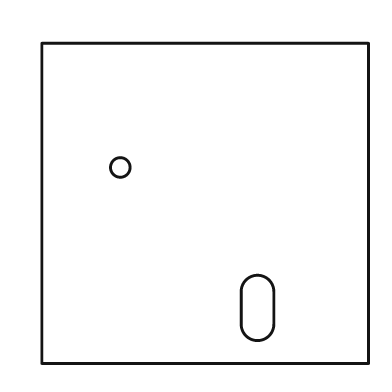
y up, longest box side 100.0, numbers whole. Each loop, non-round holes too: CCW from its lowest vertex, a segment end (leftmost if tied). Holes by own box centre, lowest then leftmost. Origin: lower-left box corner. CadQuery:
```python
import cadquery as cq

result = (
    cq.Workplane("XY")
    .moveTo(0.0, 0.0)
    .lineTo(100.0, 0.0)
    .lineTo(100.0, 98.0)
    .lineTo(0.0, 98.0)
    .close()
    .moveTo(61.0, 12.0)
    .threePointArc((66.0, 7.0), (71.0, 12.0))
    .lineTo(71.0, 22.0)
    .threePointArc((66.0, 27.0), (61.0, 22.0))
    .close()
    .moveTo(24.0, 60.0)
    .circle(3.0)
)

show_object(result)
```